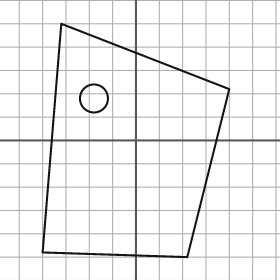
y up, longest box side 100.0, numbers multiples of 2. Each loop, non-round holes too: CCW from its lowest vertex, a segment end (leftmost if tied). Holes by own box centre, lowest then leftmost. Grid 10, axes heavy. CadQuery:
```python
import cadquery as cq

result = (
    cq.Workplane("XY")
    .moveTo(22.0, -50.0)
    .lineTo(40.0, 22.0)
    .lineTo(-32.0, 50.0)
    .lineTo(-40.0, -48.0)
    .close()
    .moveTo(-18.0, 18.0)
    .circle(6.0)
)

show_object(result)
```